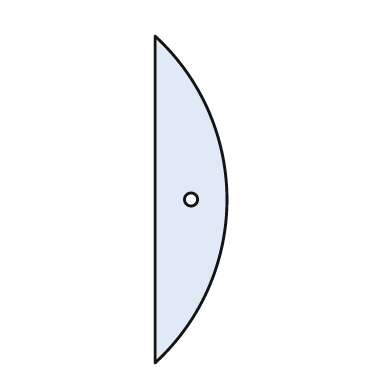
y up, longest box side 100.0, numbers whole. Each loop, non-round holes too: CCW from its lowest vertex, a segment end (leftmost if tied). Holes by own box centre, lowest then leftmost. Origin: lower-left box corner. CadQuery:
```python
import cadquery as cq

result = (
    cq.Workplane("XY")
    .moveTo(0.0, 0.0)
    .threePointArc((22.0, 50.0), (0.0, 100.0))
    .close()
    .moveTo(11.0, 50.0)
    .circle(2.0)
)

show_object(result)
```